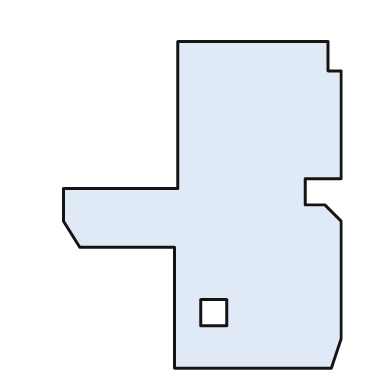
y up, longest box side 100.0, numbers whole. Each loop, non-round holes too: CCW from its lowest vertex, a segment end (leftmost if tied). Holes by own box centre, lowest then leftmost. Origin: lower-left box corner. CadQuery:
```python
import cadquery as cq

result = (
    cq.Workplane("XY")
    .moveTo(34.0, 0.0)
    .lineTo(82.0, 0.0)
    .lineTo(85.0, 9.0)
    .lineTo(85.0, 45.0)
    .lineTo(80.0, 50.0)
    .lineTo(74.0, 50.0)
    .lineTo(74.0, 58.0)
    .lineTo(85.0, 58.0)
    .lineTo(85.0, 91.0)
    .lineTo(81.0, 91.0)
    .lineTo(81.0, 100.0)
    .lineTo(35.0, 100.0)
    .lineTo(35.0, 55.0)
    .lineTo(0.0, 55.0)
    .lineTo(0.0, 45.0)
    .lineTo(5.0, 37.0)
    .lineTo(34.0, 37.0)
    .close()
    .moveTo(42.0, 13.0)
    .lineTo(50.0, 13.0)
    .lineTo(50.0, 21.0)
    .lineTo(42.0, 21.0)
    .close()
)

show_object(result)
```